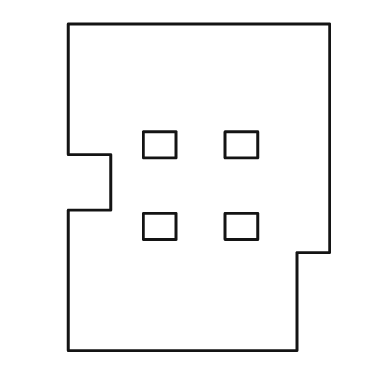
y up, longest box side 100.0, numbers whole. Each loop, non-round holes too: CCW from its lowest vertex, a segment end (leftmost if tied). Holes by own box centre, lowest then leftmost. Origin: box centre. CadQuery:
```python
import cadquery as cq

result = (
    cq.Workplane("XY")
    .moveTo(-40.0, -50.0)
    .lineTo(30.0, -50.0)
    .lineTo(30.0, -20.0)
    .lineTo(40.0, -20.0)
    .lineTo(40.0, 50.0)
    .lineTo(-40.0, 50.0)
    .lineTo(-40.0, 10.0)
    .lineTo(-27.0, 10.0)
    .lineTo(-27.0, -7.0)
    .lineTo(-40.0, -7.0)
    .close()
    .moveTo(-17.0, -16.0)
    .lineTo(-7.0, -16.0)
    .lineTo(-7.0, -8.0)
    .lineTo(-17.0, -8.0)
    .close()
    .moveTo(8.0, -16.0)
    .lineTo(18.0, -16.0)
    .lineTo(18.0, -8.0)
    .lineTo(8.0, -8.0)
    .close()
    .moveTo(-17.0, 9.0)
    .lineTo(-7.0, 9.0)
    .lineTo(-7.0, 17.0)
    .lineTo(-17.0, 17.0)
    .close()
    .moveTo(8.0, 9.0)
    .lineTo(18.0, 9.0)
    .lineTo(18.0, 17.0)
    .lineTo(8.0, 17.0)
    .close()
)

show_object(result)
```